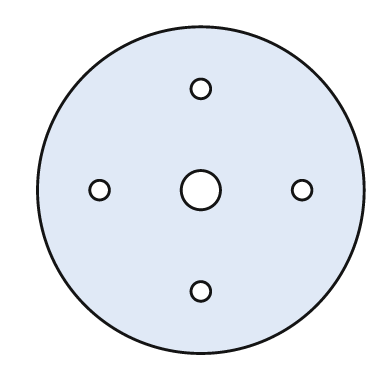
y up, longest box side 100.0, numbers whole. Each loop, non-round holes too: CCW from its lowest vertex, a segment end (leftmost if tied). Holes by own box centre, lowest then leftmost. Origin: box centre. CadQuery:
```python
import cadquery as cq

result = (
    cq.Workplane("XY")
    .moveTo(0.0, 0.0)
    .circle(50.0)
    .moveTo(0.0, -31.0)
    .circle(3.0)
    .moveTo(-31.0, 0.0)
    .circle(3.0)
    .moveTo(0.0, 0.0)
    .circle(6.0)
    .moveTo(31.0, 0.0)
    .circle(3.0)
    .moveTo(0.0, 31.0)
    .circle(3.0)
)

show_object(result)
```